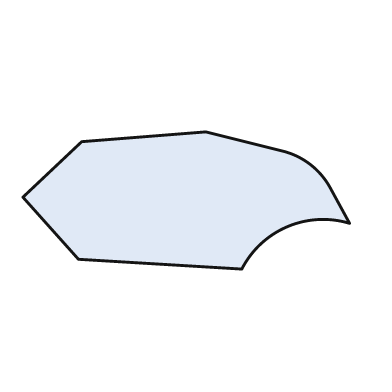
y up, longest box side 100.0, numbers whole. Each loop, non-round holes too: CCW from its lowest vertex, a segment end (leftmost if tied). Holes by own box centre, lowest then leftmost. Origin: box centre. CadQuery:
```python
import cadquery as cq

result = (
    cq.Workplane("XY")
    .moveTo(17.0, -21.0)
    .threePointArc((31.0, -8.0), (50.0, -7.0))
    .lineTo(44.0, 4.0)
    .threePointArc((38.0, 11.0), (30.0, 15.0))
    .lineTo(6.0, 21.0)
    .lineTo(-32.0, 18.0)
    .lineTo(-50.0, 1.0)
    .lineTo(-33.0, -18.0)
    .close()
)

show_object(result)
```